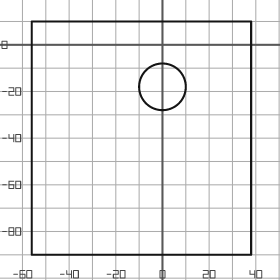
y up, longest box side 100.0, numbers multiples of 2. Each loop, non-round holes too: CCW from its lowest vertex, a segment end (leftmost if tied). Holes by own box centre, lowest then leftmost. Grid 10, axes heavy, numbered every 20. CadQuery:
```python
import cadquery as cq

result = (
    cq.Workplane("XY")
    .moveTo(-56.0, -90.0)
    .lineTo(38.0, -90.0)
    .lineTo(38.0, 10.0)
    .lineTo(-56.0, 10.0)
    .close()
    .moveTo(0.0, -18.0)
    .circle(10.0)
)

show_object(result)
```